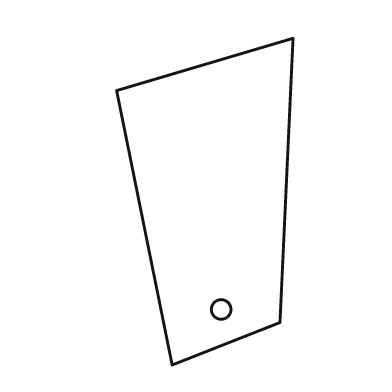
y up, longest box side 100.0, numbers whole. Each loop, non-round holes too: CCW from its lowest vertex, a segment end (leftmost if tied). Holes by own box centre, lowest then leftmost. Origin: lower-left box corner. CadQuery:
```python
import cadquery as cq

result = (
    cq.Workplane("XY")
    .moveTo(17.0, 0.0)
    .lineTo(50.0, 13.0)
    .lineTo(54.0, 100.0)
    .lineTo(0.0, 84.0)
    .close()
    .moveTo(32.0, 17.0)
    .circle(3.0)
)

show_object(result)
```